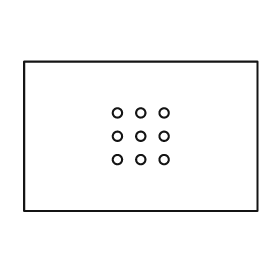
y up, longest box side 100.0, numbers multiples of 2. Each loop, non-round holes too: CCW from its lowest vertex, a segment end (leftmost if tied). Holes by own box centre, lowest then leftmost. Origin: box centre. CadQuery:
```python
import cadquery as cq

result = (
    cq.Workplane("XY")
    .moveTo(-50.0, -32.0)
    .lineTo(50.0, -32.0)
    .lineTo(50.0, 32.0)
    .lineTo(-50.0, 32.0)
    .close()
    .moveTo(-10.0, -10.0)
    .circle(2.0)
    .moveTo(0.0, -10.0)
    .circle(2.0)
    .moveTo(10.0, -10.0)
    .circle(2.0)
    .moveTo(-10.0, 0.0)
    .circle(2.0)
    .moveTo(0.0, 0.0)
    .circle(2.0)
    .moveTo(10.0, 0.0)
    .circle(2.0)
    .moveTo(-10.0, 10.0)
    .circle(2.0)
    .moveTo(0.0, 10.0)
    .circle(2.0)
    .moveTo(10.0, 10.0)
    .circle(2.0)
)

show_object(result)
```